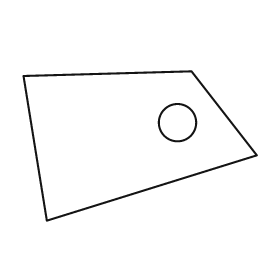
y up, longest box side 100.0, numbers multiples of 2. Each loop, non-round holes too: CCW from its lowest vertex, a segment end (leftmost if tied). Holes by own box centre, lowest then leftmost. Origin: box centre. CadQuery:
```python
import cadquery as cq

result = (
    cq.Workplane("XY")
    .moveTo(-40.0, -32.0)
    .lineTo(50.0, -4.0)
    .lineTo(22.0, 32.0)
    .lineTo(-50.0, 30.0)
    .close()
    .moveTo(16.0, 10.0)
    .circle(8.0)
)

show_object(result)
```